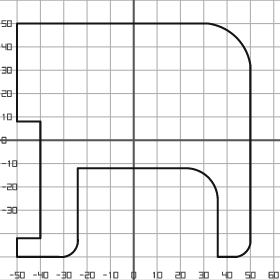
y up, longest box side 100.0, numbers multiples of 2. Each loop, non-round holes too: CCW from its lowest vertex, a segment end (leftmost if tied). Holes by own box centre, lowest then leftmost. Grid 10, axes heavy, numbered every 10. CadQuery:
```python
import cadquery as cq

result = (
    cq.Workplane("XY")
    .moveTo(-50.0, -50.0)
    .lineTo(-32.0, -50.0)
    .threePointArc((-26.0, -48.0), (-24.0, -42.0))
    .lineTo(-24.0, -12.0)
    .lineTo(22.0, -12.0)
    .threePointArc((32.0, -16.0), (36.0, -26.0))
    .lineTo(36.0, -50.0)
    .lineTo(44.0, -50.0)
    .threePointArc((48.0, -48.0), (50.0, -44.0))
    .lineTo(50.0, 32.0)
    .threePointArc((44.0, 44.0), (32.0, 50.0))
    .lineTo(-50.0, 50.0)
    .lineTo(-50.0, 8.0)
    .lineTo(-40.0, 8.0)
    .lineTo(-40.0, -42.0)
    .lineTo(-50.0, -42.0)
    .close()
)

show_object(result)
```